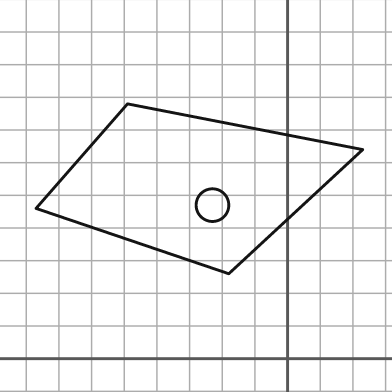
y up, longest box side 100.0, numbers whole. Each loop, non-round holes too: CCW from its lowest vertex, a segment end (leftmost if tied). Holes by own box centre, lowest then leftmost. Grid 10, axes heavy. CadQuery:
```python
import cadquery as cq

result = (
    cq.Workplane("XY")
    .moveTo(-18.0, 26.0)
    .lineTo(23.0, 64.0)
    .lineTo(-49.0, 78.0)
    .lineTo(-77.0, 46.0)
    .close()
    .moveTo(-23.0, 47.0)
    .circle(5.0)
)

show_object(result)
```